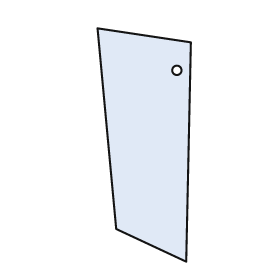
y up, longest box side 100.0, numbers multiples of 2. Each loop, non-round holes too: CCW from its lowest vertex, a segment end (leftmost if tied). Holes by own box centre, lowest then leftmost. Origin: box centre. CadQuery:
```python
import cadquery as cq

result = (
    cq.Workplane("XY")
    .moveTo(18.0, -50.0)
    .lineTo(20.0, 44.0)
    .lineTo(-20.0, 50.0)
    .lineTo(-12.0, -36.0)
    .close()
    .moveTo(14.0, 32.0)
    .circle(2.0)
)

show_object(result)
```